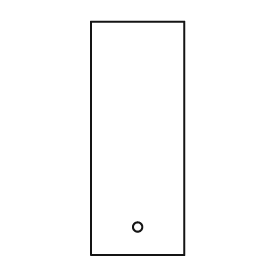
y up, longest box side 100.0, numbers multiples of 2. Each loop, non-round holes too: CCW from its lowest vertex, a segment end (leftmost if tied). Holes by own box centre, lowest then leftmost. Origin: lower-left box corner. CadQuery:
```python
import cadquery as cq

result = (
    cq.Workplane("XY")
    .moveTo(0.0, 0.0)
    .lineTo(40.0, 0.0)
    .lineTo(40.0, 100.0)
    .lineTo(0.0, 100.0)
    .close()
    .moveTo(20.0, 12.0)
    .circle(2.0)
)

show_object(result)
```